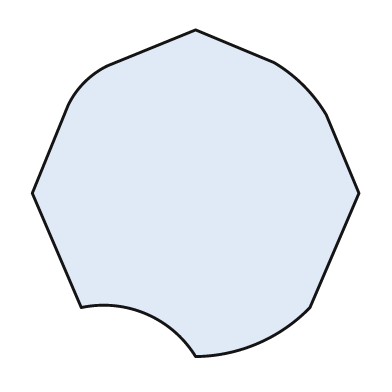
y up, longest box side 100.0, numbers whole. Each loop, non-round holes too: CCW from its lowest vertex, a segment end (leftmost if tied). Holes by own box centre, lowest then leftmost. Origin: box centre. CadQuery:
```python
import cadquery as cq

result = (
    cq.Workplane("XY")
    .moveTo(0.0, -50.0)
    .threePointArc((19.0, -46.0), (35.0, -35.0))
    .lineTo(50.0, 0.0)
    .lineTo(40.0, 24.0)
    .threePointArc((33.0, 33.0), (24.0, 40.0))
    .lineTo(0.0, 50.0)
    .lineTo(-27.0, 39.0)
    .threePointArc((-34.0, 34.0), (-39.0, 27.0))
    .lineTo(-50.0, 0.0)
    .lineTo(-35.0, -35.0)
    .threePointArc((-15.0, -37.0), (0.0, -50.0))
    .close()
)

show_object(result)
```